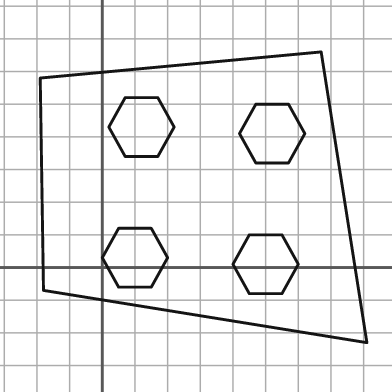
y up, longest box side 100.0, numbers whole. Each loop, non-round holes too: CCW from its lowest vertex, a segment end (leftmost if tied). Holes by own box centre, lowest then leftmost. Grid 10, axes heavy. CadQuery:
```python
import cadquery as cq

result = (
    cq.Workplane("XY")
    .moveTo(81.0, -23.0)
    .lineTo(67.0, 66.0)
    .lineTo(-19.0, 58.0)
    .lineTo(-18.0, -7.0)
    .close()
    .moveTo(45.0, -8.0)
    .lineTo(55.0, -8.0)
    .lineTo(60.0, 1.0)
    .lineTo(55.0, 10.0)
    .lineTo(45.0, 10.0)
    .lineTo(40.0, 1.0)
    .close()
    .moveTo(5.0, -6.0)
    .lineTo(15.0, -6.0)
    .lineTo(20.0, 3.0)
    .lineTo(15.0, 12.0)
    .lineTo(5.0, 12.0)
    .lineTo(0.0, 3.0)
    .close()
    .moveTo(47.0, 32.0)
    .lineTo(57.0, 32.0)
    .lineTo(62.0, 41.0)
    .lineTo(57.0, 50.0)
    .lineTo(47.0, 50.0)
    .lineTo(42.0, 41.0)
    .close()
    .moveTo(7.0, 34.0)
    .lineTo(17.0, 34.0)
    .lineTo(22.0, 43.0)
    .lineTo(17.0, 52.0)
    .lineTo(7.0, 52.0)
    .lineTo(2.0, 43.0)
    .close()
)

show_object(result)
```